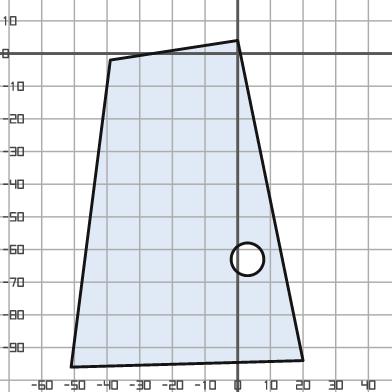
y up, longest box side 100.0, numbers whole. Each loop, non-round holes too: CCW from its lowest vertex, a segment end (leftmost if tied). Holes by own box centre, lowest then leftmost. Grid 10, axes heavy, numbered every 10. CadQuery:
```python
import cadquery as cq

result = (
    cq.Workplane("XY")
    .moveTo(-51.0, -96.0)
    .lineTo(20.0, -94.0)
    .lineTo(0.0, 4.0)
    .lineTo(-39.0, -2.0)
    .close()
    .moveTo(3.0, -63.0)
    .circle(5.0)
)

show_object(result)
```